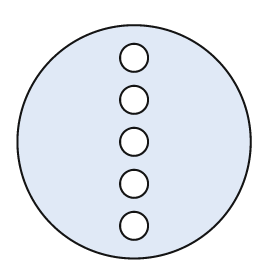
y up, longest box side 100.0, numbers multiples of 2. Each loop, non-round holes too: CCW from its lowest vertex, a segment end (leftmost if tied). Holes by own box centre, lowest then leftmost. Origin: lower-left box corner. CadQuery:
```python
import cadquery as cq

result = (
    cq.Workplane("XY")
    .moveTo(50.0, 50.0)
    .circle(50.0)
    .moveTo(50.0, 14.0)
    .circle(6.0)
    .moveTo(50.0, 32.0)
    .circle(6.0)
    .moveTo(50.0, 50.0)
    .circle(6.0)
    .moveTo(50.0, 68.0)
    .circle(6.0)
    .moveTo(50.0, 86.0)
    .circle(6.0)
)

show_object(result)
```